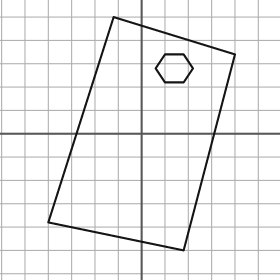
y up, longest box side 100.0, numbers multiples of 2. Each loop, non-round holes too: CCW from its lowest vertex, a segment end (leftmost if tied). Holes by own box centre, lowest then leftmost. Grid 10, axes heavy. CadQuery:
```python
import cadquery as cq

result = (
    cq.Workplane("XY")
    .moveTo(18.0, -50.0)
    .lineTo(40.0, 34.0)
    .lineTo(-12.0, 50.0)
    .lineTo(-40.0, -38.0)
    .close()
    .moveTo(10.0, 22.0)
    .lineTo(18.0, 22.0)
    .lineTo(22.0, 28.0)
    .lineTo(18.0, 34.0)
    .lineTo(10.0, 34.0)
    .lineTo(6.0, 28.0)
    .close()
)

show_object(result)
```